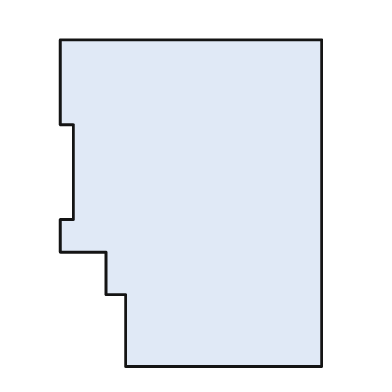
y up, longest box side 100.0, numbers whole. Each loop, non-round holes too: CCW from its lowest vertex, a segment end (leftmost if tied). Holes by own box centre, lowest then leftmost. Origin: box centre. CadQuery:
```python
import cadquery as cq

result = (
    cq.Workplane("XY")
    .moveTo(-20.0, -50.0)
    .lineTo(40.0, -50.0)
    .lineTo(40.0, 50.0)
    .lineTo(-40.0, 50.0)
    .lineTo(-40.0, 24.0)
    .lineTo(-36.0, 24.0)
    .lineTo(-36.0, -5.0)
    .lineTo(-40.0, -5.0)
    .lineTo(-40.0, -15.0)
    .lineTo(-26.0, -15.0)
    .lineTo(-26.0, -28.0)
    .lineTo(-20.0, -28.0)
    .close()
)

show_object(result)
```